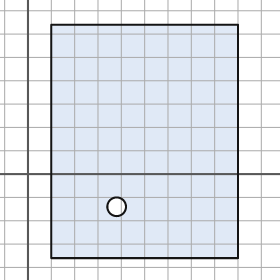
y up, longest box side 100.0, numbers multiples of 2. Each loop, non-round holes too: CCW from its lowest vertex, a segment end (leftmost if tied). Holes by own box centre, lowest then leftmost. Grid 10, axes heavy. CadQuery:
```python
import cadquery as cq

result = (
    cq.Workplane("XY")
    .moveTo(10.0, -36.0)
    .lineTo(90.0, -36.0)
    .lineTo(90.0, 64.0)
    .lineTo(10.0, 64.0)
    .close()
    .moveTo(38.0, -14.0)
    .circle(4.0)
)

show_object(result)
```